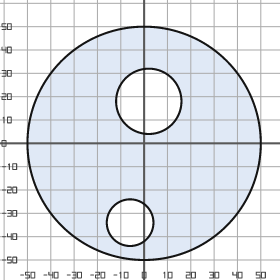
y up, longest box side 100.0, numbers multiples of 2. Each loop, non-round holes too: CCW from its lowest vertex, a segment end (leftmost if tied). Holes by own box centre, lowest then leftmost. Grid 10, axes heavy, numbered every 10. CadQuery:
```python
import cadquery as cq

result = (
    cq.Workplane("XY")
    .moveTo(0.0, 0.0)
    .circle(50.0)
    .moveTo(-6.0, -34.0)
    .circle(10.0)
    .moveTo(2.0, 18.0)
    .circle(14.0)
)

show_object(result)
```